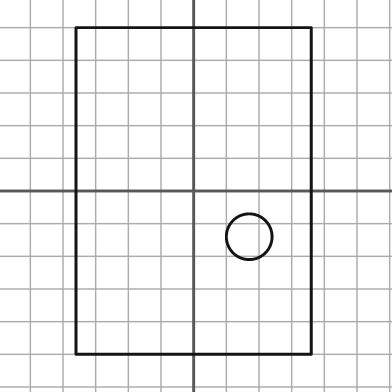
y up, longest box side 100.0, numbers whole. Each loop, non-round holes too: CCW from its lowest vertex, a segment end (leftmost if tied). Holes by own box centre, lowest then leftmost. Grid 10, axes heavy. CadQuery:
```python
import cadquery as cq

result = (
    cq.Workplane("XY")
    .moveTo(-36.0, -50.0)
    .lineTo(36.0, -50.0)
    .lineTo(36.0, 50.0)
    .lineTo(-36.0, 50.0)
    .close()
    .moveTo(17.0, -14.0)
    .circle(7.0)
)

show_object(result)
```